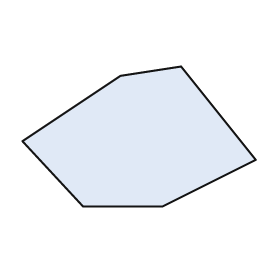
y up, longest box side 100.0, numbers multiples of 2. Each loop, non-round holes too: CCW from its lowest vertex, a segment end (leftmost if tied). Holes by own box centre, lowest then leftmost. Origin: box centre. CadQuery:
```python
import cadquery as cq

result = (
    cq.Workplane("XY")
    .moveTo(-24.0, -30.0)
    .lineTo(10.0, -30.0)
    .lineTo(50.0, -10.0)
    .lineTo(18.0, 30.0)
    .lineTo(-8.0, 26.0)
    .lineTo(-50.0, -2.0)
    .close()
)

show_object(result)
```